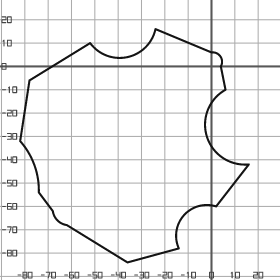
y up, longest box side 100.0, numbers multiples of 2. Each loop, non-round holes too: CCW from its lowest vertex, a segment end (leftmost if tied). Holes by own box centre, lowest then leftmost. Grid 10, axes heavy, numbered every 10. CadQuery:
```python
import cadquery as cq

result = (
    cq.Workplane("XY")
    .moveTo(-36.0, -84.0)
    .lineTo(-14.0, -78.0)
    .threePointArc((-12.0, -64.0), (2.0, -60.0))
    .lineTo(16.0, -42.0)
    .threePointArc((-2.0, -30.0), (6.0, -10.0))
    .lineTo(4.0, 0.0)
    .threePointArc((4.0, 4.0), (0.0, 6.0))
    .lineTo(-24.0, 16.0)
    .threePointArc((-36.0, 4.0), (-52.0, 10.0))
    .lineTo(-78.0, -6.0)
    .lineTo(-82.0, -32.0)
    .threePointArc((-76.0, -42.0), (-74.0, -54.0))
    .lineTo(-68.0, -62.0)
    .threePointArc((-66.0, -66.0), (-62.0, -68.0))
    .close()
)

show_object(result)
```